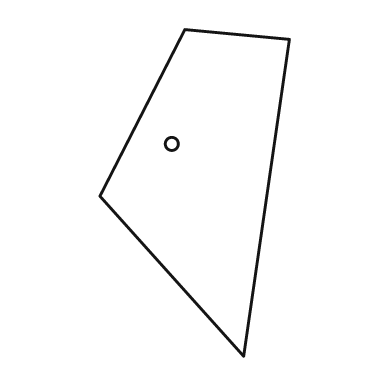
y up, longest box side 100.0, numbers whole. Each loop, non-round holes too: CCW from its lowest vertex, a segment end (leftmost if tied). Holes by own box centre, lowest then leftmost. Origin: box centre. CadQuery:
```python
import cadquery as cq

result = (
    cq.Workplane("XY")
    .moveTo(15.0, -50.0)
    .lineTo(29.0, 47.0)
    .lineTo(-3.0, 50.0)
    .lineTo(-29.0, -1.0)
    .close()
    .moveTo(-7.0, 15.0)
    .circle(2.0)
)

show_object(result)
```